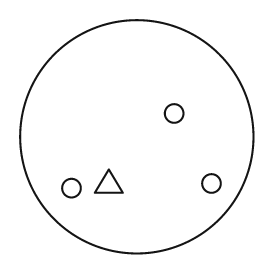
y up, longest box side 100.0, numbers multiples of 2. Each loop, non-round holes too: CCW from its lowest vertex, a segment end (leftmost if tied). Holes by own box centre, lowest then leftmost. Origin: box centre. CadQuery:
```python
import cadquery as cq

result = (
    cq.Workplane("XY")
    .moveTo(0.0, 0.0)
    .circle(50.0)
    .moveTo(-28.0, -22.0)
    .circle(4.0)
    .moveTo(32.0, -20.0)
    .circle(4.0)
    .moveTo(-18.0, -24.0)
    .lineTo(-6.0, -24.0)
    .lineTo(-12.0, -14.0)
    .close()
    .moveTo(16.0, 10.0)
    .circle(4.0)
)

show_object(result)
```